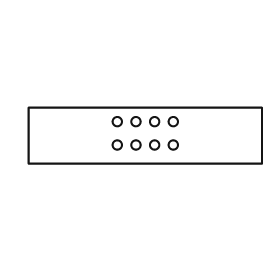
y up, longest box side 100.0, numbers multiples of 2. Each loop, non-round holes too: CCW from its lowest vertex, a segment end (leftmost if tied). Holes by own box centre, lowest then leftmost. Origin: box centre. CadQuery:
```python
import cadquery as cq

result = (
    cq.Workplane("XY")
    .moveTo(-50.0, -12.0)
    .lineTo(50.0, -12.0)
    .lineTo(50.0, 12.0)
    .lineTo(-50.0, 12.0)
    .close()
    .moveTo(-12.0, -4.0)
    .circle(2.0)
    .moveTo(-4.0, -4.0)
    .circle(2.0)
    .moveTo(4.0, -4.0)
    .circle(2.0)
    .moveTo(12.0, -4.0)
    .circle(2.0)
    .moveTo(-12.0, 6.0)
    .circle(2.0)
    .moveTo(-4.0, 6.0)
    .circle(2.0)
    .moveTo(4.0, 6.0)
    .circle(2.0)
    .moveTo(12.0, 6.0)
    .circle(2.0)
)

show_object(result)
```